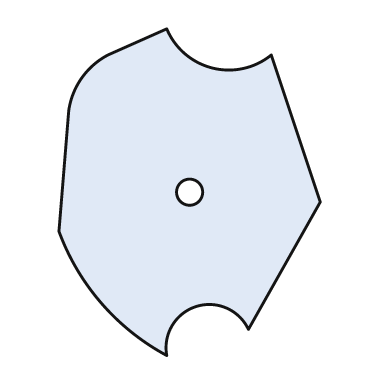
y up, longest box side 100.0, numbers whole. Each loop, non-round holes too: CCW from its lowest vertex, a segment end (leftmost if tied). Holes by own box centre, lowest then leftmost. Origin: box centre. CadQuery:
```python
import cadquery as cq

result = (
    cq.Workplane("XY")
    .moveTo(-7.0, -50.0)
    .threePointArc((2.0, -35.0), (18.0, -42.0))
    .lineTo(40.0, -3.0)
    .lineTo(25.0, 42.0)
    .threePointArc((7.0, 38.0), (-7.0, 50.0))
    .lineTo(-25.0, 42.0)
    .threePointArc((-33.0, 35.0), (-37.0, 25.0))
    .lineTo(-40.0, -12.0)
    .threePointArc((-27.0, -34.0), (-7.0, -50.0))
    .close()
    .moveTo(0.0, 0.0)
    .circle(4.0)
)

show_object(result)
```